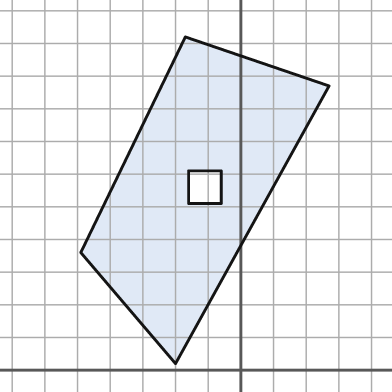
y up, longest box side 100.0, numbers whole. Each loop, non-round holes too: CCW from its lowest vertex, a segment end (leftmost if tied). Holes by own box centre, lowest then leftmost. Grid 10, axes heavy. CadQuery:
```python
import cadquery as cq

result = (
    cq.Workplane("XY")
    .moveTo(-20.0, 2.0)
    .lineTo(27.0, 87.0)
    .lineTo(-17.0, 102.0)
    .lineTo(-49.0, 36.0)
    .close()
    .moveTo(-16.0, 51.0)
    .lineTo(-6.0, 51.0)
    .lineTo(-6.0, 61.0)
    .lineTo(-16.0, 61.0)
    .close()
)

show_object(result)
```